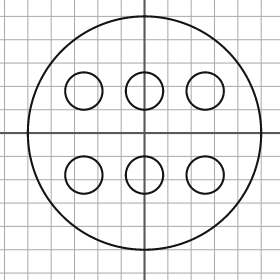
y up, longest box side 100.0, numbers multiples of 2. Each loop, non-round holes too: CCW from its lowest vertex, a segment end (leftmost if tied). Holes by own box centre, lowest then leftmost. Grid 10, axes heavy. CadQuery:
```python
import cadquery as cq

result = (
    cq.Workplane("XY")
    .moveTo(0.0, 0.0)
    .circle(50.0)
    .moveTo(-26.0, -18.0)
    .circle(8.0)
    .moveTo(0.0, -18.0)
    .circle(8.0)
    .moveTo(26.0, -18.0)
    .circle(8.0)
    .moveTo(-26.0, 18.0)
    .circle(8.0)
    .moveTo(0.0, 18.0)
    .circle(8.0)
    .moveTo(26.0, 18.0)
    .circle(8.0)
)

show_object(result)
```